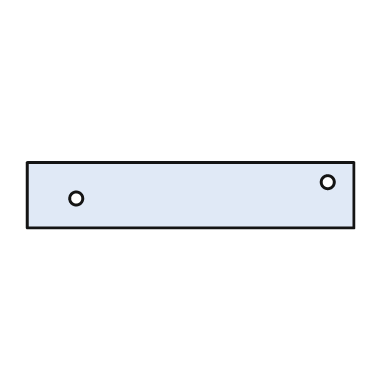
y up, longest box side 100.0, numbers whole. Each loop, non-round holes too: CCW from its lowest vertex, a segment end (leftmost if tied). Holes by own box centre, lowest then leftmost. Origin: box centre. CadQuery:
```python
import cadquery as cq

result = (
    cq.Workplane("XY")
    .moveTo(-50.0, -10.0)
    .lineTo(50.0, -10.0)
    .lineTo(50.0, 10.0)
    .lineTo(-50.0, 10.0)
    .close()
    .moveTo(-35.0, -1.0)
    .circle(2.0)
    .moveTo(42.0, 4.0)
    .circle(2.0)
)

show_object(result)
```